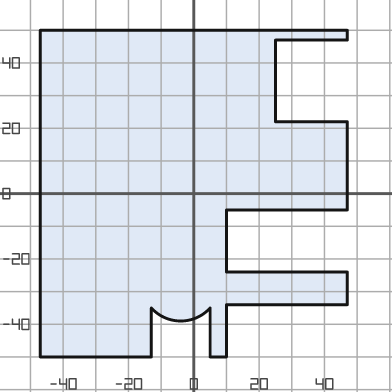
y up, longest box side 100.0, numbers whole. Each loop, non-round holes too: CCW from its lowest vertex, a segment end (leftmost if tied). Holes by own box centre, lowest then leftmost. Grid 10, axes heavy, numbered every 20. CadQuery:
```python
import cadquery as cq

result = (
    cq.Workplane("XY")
    .moveTo(-47.0, -50.0)
    .lineTo(-13.0, -50.0)
    .lineTo(-13.0, -35.0)
    .threePointArc((-4.0, -39.0), (5.0, -35.0))
    .lineTo(5.0, -50.0)
    .lineTo(10.0, -50.0)
    .lineTo(10.0, -34.0)
    .lineTo(47.0, -34.0)
    .lineTo(47.0, -24.0)
    .lineTo(10.0, -24.0)
    .lineTo(10.0, -5.0)
    .lineTo(47.0, -5.0)
    .lineTo(47.0, 22.0)
    .lineTo(25.0, 22.0)
    .lineTo(25.0, 47.0)
    .lineTo(47.0, 47.0)
    .lineTo(47.0, 50.0)
    .lineTo(-47.0, 50.0)
    .close()
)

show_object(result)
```